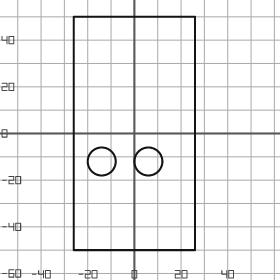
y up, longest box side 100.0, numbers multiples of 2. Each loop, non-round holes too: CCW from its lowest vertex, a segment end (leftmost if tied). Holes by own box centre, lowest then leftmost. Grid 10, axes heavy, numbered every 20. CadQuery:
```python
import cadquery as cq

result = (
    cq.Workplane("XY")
    .moveTo(-26.0, -50.0)
    .lineTo(26.0, -50.0)
    .lineTo(26.0, 50.0)
    .lineTo(-26.0, 50.0)
    .close()
    .moveTo(-14.0, -12.0)
    .circle(6.0)
    .moveTo(6.0, -12.0)
    .circle(6.0)
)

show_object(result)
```